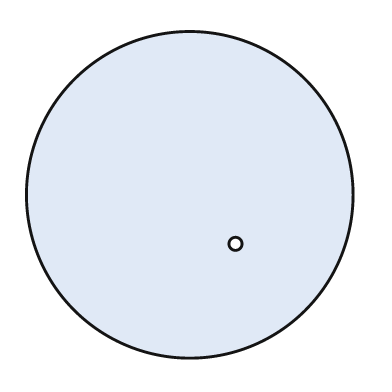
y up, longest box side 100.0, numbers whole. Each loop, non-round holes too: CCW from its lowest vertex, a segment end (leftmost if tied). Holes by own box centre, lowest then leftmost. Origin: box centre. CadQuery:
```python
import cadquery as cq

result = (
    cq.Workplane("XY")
    .moveTo(0.0, 0.0)
    .circle(50.0)
    .moveTo(14.0, -15.0)
    .circle(2.0)
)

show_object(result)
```